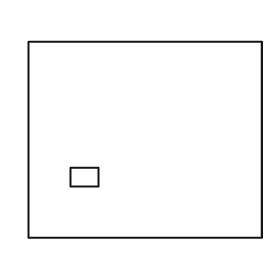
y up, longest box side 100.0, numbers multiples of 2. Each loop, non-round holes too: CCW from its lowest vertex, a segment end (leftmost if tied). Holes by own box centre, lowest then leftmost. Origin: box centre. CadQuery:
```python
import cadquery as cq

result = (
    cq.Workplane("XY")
    .moveTo(-50.0, -42.0)
    .lineTo(50.0, -42.0)
    .lineTo(50.0, 42.0)
    .lineTo(-50.0, 42.0)
    .close()
    .moveTo(-32.0, -20.0)
    .lineTo(-20.0, -20.0)
    .lineTo(-20.0, -12.0)
    .lineTo(-32.0, -12.0)
    .close()
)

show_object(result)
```